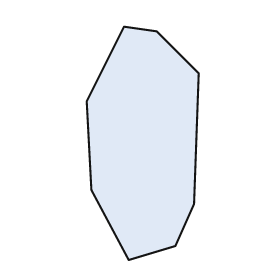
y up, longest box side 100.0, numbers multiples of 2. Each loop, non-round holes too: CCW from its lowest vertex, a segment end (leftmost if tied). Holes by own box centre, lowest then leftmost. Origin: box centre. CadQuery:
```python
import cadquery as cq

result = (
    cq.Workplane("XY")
    .moveTo(-6.0, -50.0)
    .lineTo(14.0, -44.0)
    .lineTo(22.0, -26.0)
    .lineTo(24.0, 30.0)
    .lineTo(6.0, 48.0)
    .lineTo(-8.0, 50.0)
    .lineTo(-24.0, 18.0)
    .lineTo(-22.0, -20.0)
    .close()
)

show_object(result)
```